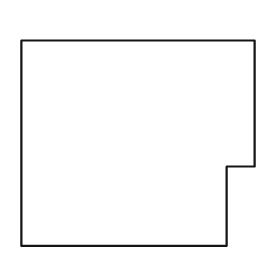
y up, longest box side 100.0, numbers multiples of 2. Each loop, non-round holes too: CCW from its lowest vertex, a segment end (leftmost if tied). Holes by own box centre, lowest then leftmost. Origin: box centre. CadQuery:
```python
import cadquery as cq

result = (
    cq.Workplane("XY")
    .moveTo(-50.0, -44.0)
    .lineTo(38.0, -44.0)
    .lineTo(38.0, -10.0)
    .lineTo(50.0, -10.0)
    .lineTo(50.0, 44.0)
    .lineTo(-50.0, 44.0)
    .close()
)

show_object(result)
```